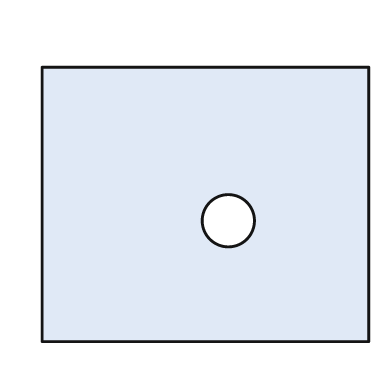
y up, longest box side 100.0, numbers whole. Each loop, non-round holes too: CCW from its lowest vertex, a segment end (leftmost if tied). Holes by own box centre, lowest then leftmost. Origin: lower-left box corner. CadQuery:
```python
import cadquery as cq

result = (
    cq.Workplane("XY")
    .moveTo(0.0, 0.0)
    .lineTo(100.0, 0.0)
    .lineTo(100.0, 84.0)
    .lineTo(0.0, 84.0)
    .close()
    .moveTo(57.0, 37.0)
    .circle(8.0)
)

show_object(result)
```